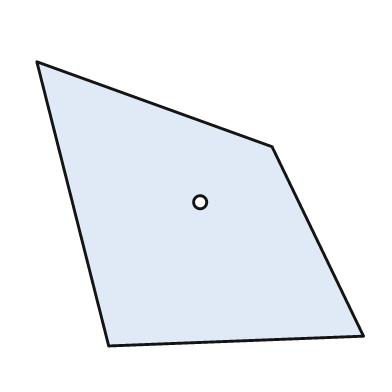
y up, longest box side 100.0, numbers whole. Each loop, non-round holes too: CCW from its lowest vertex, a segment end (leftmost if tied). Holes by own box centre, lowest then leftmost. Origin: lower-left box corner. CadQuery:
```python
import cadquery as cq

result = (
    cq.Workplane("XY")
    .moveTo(22.0, 0.0)
    .lineTo(100.0, 3.0)
    .lineTo(72.0, 61.0)
    .lineTo(0.0, 87.0)
    .close()
    .moveTo(50.0, 44.0)
    .circle(2.0)
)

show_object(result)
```